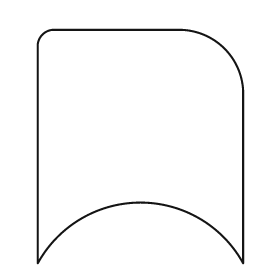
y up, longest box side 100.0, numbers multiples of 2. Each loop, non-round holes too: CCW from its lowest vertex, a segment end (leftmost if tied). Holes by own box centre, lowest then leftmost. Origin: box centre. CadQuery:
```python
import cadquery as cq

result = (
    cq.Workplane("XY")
    .moveTo(-44.0, -50.0)
    .threePointArc((0.0, -24.0), (44.0, -50.0))
    .lineTo(44.0, 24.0)
    .threePointArc((36.0, 42.0), (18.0, 50.0))
    .lineTo(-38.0, 50.0)
    .threePointArc((-42.0, 48.0), (-44.0, 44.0))
    .close()
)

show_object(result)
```